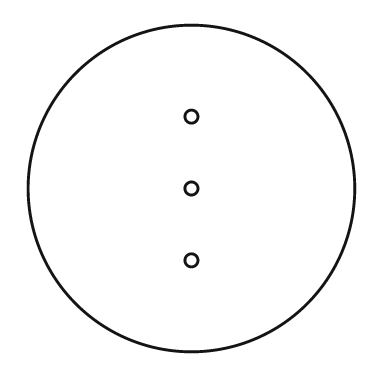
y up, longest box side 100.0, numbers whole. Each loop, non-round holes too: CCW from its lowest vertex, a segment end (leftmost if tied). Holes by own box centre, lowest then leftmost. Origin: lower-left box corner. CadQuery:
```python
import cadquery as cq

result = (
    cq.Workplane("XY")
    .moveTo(50.0, 50.0)
    .circle(50.0)
    .moveTo(50.0, 28.0)
    .circle(2.0)
    .moveTo(50.0, 50.0)
    .circle(2.0)
    .moveTo(50.0, 72.0)
    .circle(2.0)
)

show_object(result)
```